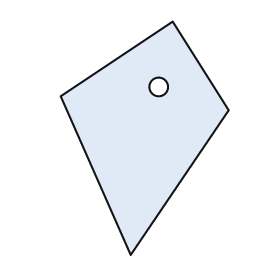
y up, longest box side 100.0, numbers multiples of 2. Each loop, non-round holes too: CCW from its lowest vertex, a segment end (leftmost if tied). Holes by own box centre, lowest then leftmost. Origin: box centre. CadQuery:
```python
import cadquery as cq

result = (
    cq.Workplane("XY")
    .moveTo(-6.0, -50.0)
    .lineTo(36.0, 12.0)
    .lineTo(12.0, 50.0)
    .lineTo(-36.0, 18.0)
    .close()
    .moveTo(6.0, 22.0)
    .circle(4.0)
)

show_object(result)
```